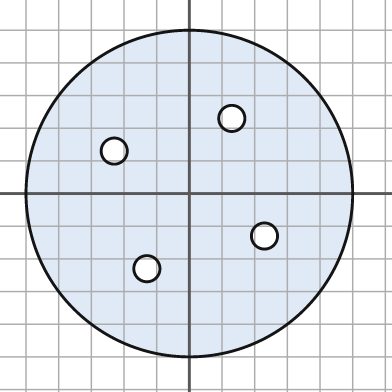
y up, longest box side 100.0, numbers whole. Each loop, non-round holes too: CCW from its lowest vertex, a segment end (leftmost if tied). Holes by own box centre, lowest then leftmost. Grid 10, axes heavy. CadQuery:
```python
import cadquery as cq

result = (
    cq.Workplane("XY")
    .moveTo(0.0, 0.0)
    .circle(50.0)
    .moveTo(-13.0, -23.0)
    .circle(4.0)
    .moveTo(23.0, -13.0)
    .circle(4.0)
    .moveTo(-23.0, 13.0)
    .circle(4.0)
    .moveTo(13.0, 23.0)
    .circle(4.0)
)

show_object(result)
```